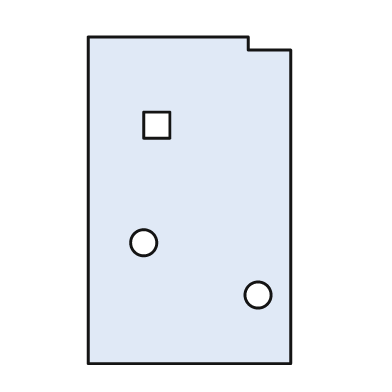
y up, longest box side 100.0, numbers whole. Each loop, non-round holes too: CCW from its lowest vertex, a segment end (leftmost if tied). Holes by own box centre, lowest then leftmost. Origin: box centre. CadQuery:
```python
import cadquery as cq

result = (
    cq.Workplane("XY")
    .moveTo(-31.0, -50.0)
    .lineTo(31.0, -50.0)
    .lineTo(31.0, 46.0)
    .lineTo(18.0, 46.0)
    .lineTo(18.0, 50.0)
    .lineTo(-31.0, 50.0)
    .close()
    .moveTo(21.0, -29.0)
    .circle(4.0)
    .moveTo(-14.0, -13.0)
    .circle(4.0)
    .moveTo(-14.0, 19.0)
    .lineTo(-6.0, 19.0)
    .lineTo(-6.0, 27.0)
    .lineTo(-14.0, 27.0)
    .close()
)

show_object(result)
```